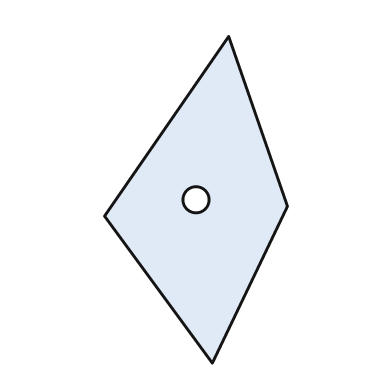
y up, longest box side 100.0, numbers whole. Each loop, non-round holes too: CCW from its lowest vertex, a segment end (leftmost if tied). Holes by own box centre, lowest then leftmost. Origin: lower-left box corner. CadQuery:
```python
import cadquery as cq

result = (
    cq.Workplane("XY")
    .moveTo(33.0, 0.0)
    .lineTo(56.0, 48.0)
    .lineTo(38.0, 100.0)
    .lineTo(0.0, 45.0)
    .close()
    .moveTo(28.0, 50.0)
    .circle(4.0)
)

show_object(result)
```